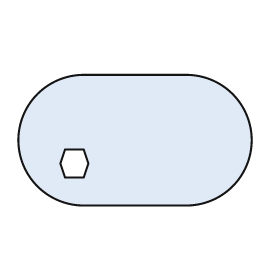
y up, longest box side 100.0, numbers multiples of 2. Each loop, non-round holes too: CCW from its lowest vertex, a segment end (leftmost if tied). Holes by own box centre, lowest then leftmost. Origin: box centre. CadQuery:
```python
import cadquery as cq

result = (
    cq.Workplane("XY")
    .moveTo(-22.0, -28.0)
    .lineTo(22.0, -28.0)
    .threePointArc((50.0, 0.0), (22.0, 28.0))
    .lineTo(-22.0, 28.0)
    .threePointArc((-50.0, 0.0), (-22.0, -28.0))
    .close()
    .moveTo(-30.0, -16.0)
    .lineTo(-22.0, -16.0)
    .lineTo(-20.0, -10.0)
    .lineTo(-22.0, -4.0)
    .lineTo(-30.0, -4.0)
    .lineTo(-32.0, -10.0)
    .close()
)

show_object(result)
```